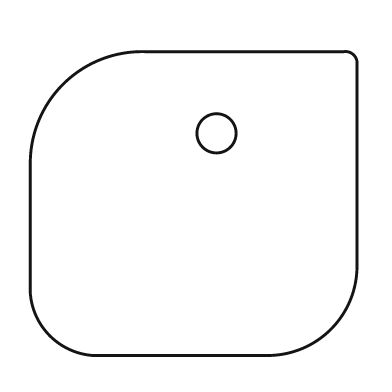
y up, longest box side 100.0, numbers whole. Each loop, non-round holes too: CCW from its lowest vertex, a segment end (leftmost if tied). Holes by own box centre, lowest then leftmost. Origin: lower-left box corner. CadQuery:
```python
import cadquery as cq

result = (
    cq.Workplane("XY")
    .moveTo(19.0, 0.0)
    .lineTo(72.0, 0.0)
    .threePointArc((92.0, 8.0), (100.0, 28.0))
    .lineTo(100.0, 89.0)
    .threePointArc((99.0, 92.0), (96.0, 93.0))
    .lineTo(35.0, 93.0)
    .threePointArc((10.0, 83.0), (0.0, 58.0))
    .lineTo(0.0, 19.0)
    .threePointArc((6.0, 6.0), (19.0, 0.0))
    .close()
    .moveTo(57.0, 68.0)
    .circle(6.0)
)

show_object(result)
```